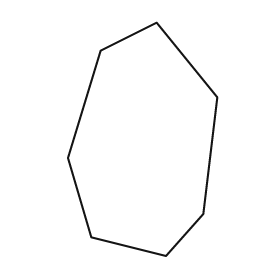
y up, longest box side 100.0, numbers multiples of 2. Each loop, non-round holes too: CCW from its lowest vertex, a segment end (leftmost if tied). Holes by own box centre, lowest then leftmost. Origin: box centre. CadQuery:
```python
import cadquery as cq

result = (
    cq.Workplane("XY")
    .moveTo(10.0, -50.0)
    .lineTo(26.0, -32.0)
    .lineTo(32.0, 18.0)
    .lineTo(6.0, 50.0)
    .lineTo(-18.0, 38.0)
    .lineTo(-32.0, -8.0)
    .lineTo(-22.0, -42.0)
    .close()
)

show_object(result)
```